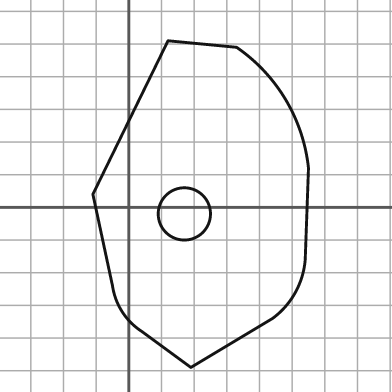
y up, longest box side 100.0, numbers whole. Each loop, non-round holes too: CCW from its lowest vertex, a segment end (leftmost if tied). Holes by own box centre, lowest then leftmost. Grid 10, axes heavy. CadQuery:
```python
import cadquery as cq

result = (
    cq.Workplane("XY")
    .moveTo(19.0, -49.0)
    .lineTo(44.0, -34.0)
    .threePointArc((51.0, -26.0), (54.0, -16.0))
    .lineTo(55.0, 12.0)
    .threePointArc((48.0, 33.0), (33.0, 49.0))
    .lineTo(12.0, 51.0)
    .lineTo(-11.0, 4.0)
    .lineTo(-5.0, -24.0)
    .threePointArc((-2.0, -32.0), (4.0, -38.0))
    .close()
    .moveTo(17.0, -2.0)
    .circle(8.0)
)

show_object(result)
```